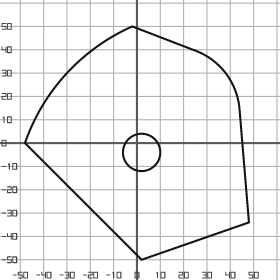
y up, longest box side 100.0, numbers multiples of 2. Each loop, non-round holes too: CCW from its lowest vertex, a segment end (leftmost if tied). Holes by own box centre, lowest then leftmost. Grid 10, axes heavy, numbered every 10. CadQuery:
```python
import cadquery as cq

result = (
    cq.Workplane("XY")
    .moveTo(2.0, -50.0)
    .lineTo(48.0, -34.0)
    .lineTo(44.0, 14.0)
    .threePointArc((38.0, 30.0), (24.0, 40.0))
    .lineTo(-2.0, 50.0)
    .threePointArc((-30.0, 30.0), (-48.0, 0.0))
    .close()
    .moveTo(2.0, -4.0)
    .circle(8.0)
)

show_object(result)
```